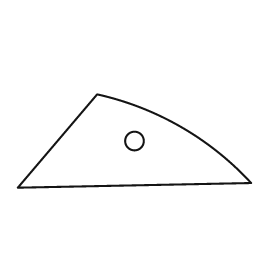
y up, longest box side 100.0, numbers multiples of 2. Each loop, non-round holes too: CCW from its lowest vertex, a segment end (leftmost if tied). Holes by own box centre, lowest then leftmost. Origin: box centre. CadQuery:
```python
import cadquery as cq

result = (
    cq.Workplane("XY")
    .moveTo(-50.0, -20.0)
    .lineTo(50.0, -18.0)
    .threePointArc((20.0, 6.0), (-16.0, 20.0))
    .close()
    .moveTo(0.0, 0.0)
    .circle(4.0)
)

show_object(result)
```